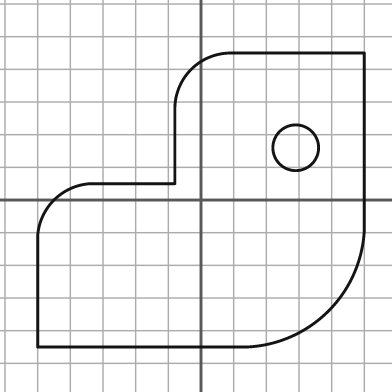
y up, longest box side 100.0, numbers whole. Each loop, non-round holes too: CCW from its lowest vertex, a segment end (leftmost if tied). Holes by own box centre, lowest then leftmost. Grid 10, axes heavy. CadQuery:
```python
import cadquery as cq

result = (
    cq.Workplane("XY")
    .moveTo(-50.0, -45.0)
    .lineTo(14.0, -45.0)
    .threePointArc((39.0, -34.0), (50.0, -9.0))
    .lineTo(50.0, 45.0)
    .lineTo(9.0, 45.0)
    .threePointArc((-3.0, 40.0), (-8.0, 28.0))
    .lineTo(-8.0, 5.0)
    .lineTo(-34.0, 5.0)
    .threePointArc((-45.0, 0.0), (-50.0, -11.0))
    .close()
    .moveTo(29.0, 16.0)
    .circle(7.0)
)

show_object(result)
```